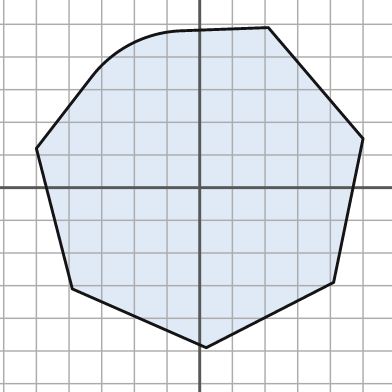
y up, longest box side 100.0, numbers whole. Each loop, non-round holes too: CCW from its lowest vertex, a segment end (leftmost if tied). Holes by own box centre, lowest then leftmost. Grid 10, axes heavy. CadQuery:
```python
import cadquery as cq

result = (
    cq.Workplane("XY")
    .moveTo(2.0, -49.0)
    .lineTo(41.0, -29.0)
    .lineTo(50.0, 15.0)
    .lineTo(21.0, 49.0)
    .lineTo(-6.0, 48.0)
    .threePointArc((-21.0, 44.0), (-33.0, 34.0))
    .lineTo(-50.0, 12.0)
    .lineTo(-39.0, -31.0)
    .close()
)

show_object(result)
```